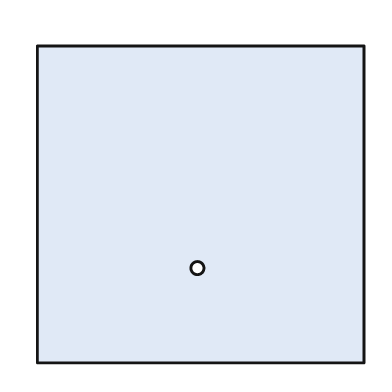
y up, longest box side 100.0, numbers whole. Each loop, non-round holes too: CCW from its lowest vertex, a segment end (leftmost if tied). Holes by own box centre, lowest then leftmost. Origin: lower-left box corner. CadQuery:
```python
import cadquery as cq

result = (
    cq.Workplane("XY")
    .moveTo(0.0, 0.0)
    .lineTo(100.0, 0.0)
    .lineTo(100.0, 97.0)
    .lineTo(0.0, 97.0)
    .close()
    .moveTo(49.0, 29.0)
    .circle(2.0)
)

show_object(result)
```